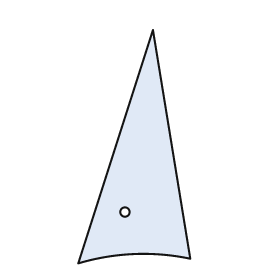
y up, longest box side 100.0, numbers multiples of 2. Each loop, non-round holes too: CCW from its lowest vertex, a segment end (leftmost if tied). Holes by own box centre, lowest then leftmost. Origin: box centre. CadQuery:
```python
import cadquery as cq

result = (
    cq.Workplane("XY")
    .moveTo(-24.0, -50.0)
    .threePointArc((0.0, -46.0), (24.0, -48.0))
    .lineTo(8.0, 50.0)
    .close()
    .moveTo(-4.0, -28.0)
    .circle(2.0)
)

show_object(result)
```